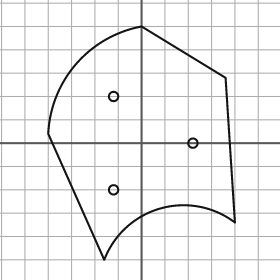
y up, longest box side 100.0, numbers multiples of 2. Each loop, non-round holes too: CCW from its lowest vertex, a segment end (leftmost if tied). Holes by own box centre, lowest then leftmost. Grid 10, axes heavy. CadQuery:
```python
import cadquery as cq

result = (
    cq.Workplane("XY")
    .moveTo(-16.0, -50.0)
    .threePointArc((8.0, -28.0), (40.0, -34.0))
    .lineTo(36.0, 28.0)
    .lineTo(0.0, 50.0)
    .threePointArc((-28.0, 34.0), (-40.0, 4.0))
    .close()
    .moveTo(-12.0, -20.0)
    .circle(2.0)
    .moveTo(22.0, 0.0)
    .circle(2.0)
    .moveTo(-12.0, 20.0)
    .circle(2.0)
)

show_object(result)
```